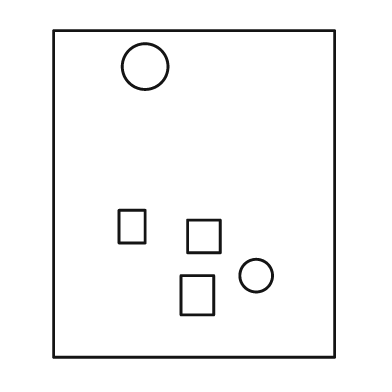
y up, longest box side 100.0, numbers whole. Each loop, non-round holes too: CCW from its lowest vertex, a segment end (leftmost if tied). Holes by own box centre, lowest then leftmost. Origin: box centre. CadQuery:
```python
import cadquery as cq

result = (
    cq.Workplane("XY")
    .moveTo(-43.0, -50.0)
    .lineTo(43.0, -50.0)
    .lineTo(43.0, 50.0)
    .lineTo(-43.0, 50.0)
    .close()
    .moveTo(-4.0, -37.0)
    .lineTo(6.0, -37.0)
    .lineTo(6.0, -25.0)
    .lineTo(-4.0, -25.0)
    .close()
    .moveTo(19.0, -25.0)
    .circle(5.0)
    .moveTo(-2.0, -18.0)
    .lineTo(8.0, -18.0)
    .lineTo(8.0, -8.0)
    .lineTo(-2.0, -8.0)
    .close()
    .moveTo(-23.0, -15.0)
    .lineTo(-15.0, -15.0)
    .lineTo(-15.0, -5.0)
    .lineTo(-23.0, -5.0)
    .close()
    .moveTo(-15.0, 39.0)
    .circle(7.0)
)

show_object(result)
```